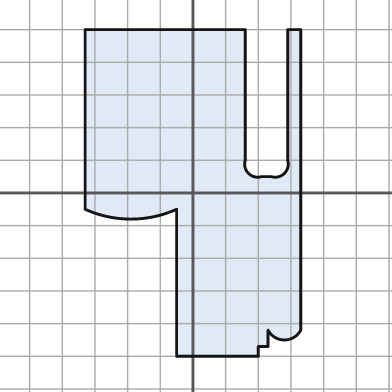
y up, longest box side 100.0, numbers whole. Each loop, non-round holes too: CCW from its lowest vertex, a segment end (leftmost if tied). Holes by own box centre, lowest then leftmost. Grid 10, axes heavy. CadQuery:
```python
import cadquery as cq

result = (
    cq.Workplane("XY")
    .moveTo(-5.0, -50.0)
    .lineTo(20.0, -50.0)
    .lineTo(20.0, -47.0)
    .lineTo(23.0, -47.0)
    .lineTo(23.0, -42.0)
    .threePointArc((28.0, -45.0), (33.0, -42.0))
    .lineTo(33.0, 50.0)
    .lineTo(29.0, 50.0)
    .lineTo(29.0, 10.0)
    .threePointArc((28.0, 6.0), (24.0, 5.0))
    .lineTo(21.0, 5.0)
    .threePointArc((17.0, 6.0), (16.0, 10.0))
    .lineTo(16.0, 50.0)
    .lineTo(-33.0, 50.0)
    .lineTo(-33.0, -5.0)
    .threePointArc((-19.0, -8.0), (-5.0, -5.0))
    .close()
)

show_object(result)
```